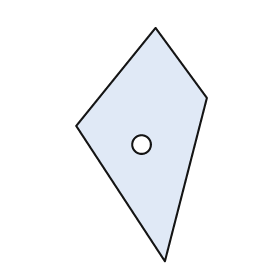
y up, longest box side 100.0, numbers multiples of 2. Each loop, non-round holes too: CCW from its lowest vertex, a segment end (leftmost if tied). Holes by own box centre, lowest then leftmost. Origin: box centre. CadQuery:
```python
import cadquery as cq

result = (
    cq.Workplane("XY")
    .moveTo(10.0, -50.0)
    .lineTo(28.0, 20.0)
    .lineTo(6.0, 50.0)
    .lineTo(-28.0, 8.0)
    .close()
    .moveTo(0.0, 0.0)
    .circle(4.0)
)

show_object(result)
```